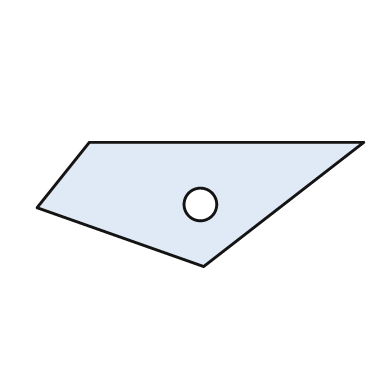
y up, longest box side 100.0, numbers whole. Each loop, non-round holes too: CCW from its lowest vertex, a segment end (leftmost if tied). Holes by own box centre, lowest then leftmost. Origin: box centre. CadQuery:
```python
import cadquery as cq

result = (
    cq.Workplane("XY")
    .moveTo(1.0, -19.0)
    .lineTo(50.0, 19.0)
    .lineTo(-34.0, 19.0)
    .lineTo(-50.0, -1.0)
    .close()
    .moveTo(0.0, 0.0)
    .circle(5.0)
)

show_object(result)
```